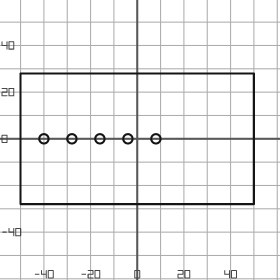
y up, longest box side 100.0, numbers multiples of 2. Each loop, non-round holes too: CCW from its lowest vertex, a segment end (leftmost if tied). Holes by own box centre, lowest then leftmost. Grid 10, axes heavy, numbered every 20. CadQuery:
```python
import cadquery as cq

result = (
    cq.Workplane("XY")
    .moveTo(-50.0, -28.0)
    .lineTo(50.0, -28.0)
    .lineTo(50.0, 28.0)
    .lineTo(-50.0, 28.0)
    .close()
    .moveTo(-40.0, 0.0)
    .circle(2.0)
    .moveTo(-28.0, 0.0)
    .circle(2.0)
    .moveTo(-16.0, 0.0)
    .circle(2.0)
    .moveTo(-4.0, 0.0)
    .circle(2.0)
    .moveTo(8.0, 0.0)
    .circle(2.0)
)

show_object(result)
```